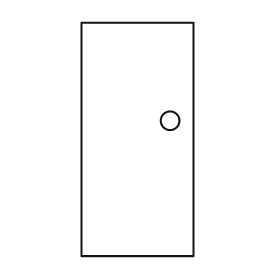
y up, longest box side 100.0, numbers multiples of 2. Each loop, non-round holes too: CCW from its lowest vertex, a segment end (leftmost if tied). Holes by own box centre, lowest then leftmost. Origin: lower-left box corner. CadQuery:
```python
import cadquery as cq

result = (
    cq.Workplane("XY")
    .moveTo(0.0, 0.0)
    .lineTo(48.0, 0.0)
    .lineTo(48.0, 100.0)
    .lineTo(0.0, 100.0)
    .close()
    .moveTo(38.0, 58.0)
    .circle(4.0)
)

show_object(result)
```